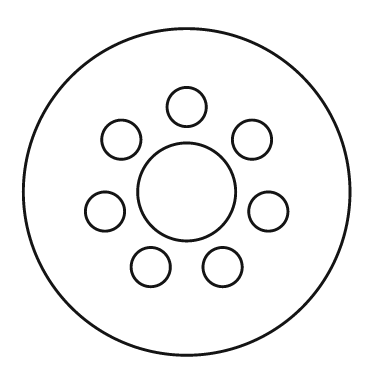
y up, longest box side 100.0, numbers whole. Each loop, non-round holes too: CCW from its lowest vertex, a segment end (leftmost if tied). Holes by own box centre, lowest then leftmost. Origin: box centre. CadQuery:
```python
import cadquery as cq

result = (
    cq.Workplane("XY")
    .moveTo(0.0, 0.0)
    .circle(50.0)
    .moveTo(-11.0, -23.0)
    .circle(6.0)
    .moveTo(11.0, -23.0)
    .circle(6.0)
    .moveTo(-25.0, -6.0)
    .circle(6.0)
    .moveTo(25.0, -6.0)
    .circle(6.0)
    .moveTo(0.0, 0.0)
    .circle(15.0)
    .moveTo(-20.0, 16.0)
    .circle(6.0)
    .moveTo(20.0, 16.0)
    .circle(6.0)
    .moveTo(0.0, 26.0)
    .circle(6.0)
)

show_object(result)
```